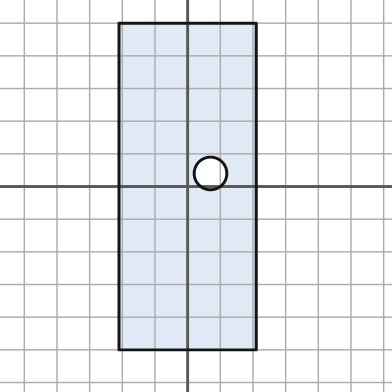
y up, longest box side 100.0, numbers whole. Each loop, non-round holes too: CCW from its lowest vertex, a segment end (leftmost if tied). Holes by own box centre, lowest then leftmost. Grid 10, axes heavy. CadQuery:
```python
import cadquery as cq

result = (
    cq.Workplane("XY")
    .moveTo(-21.0, -50.0)
    .lineTo(21.0, -50.0)
    .lineTo(21.0, 50.0)
    .lineTo(-21.0, 50.0)
    .close()
    .moveTo(7.0, 4.0)
    .circle(5.0)
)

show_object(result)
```